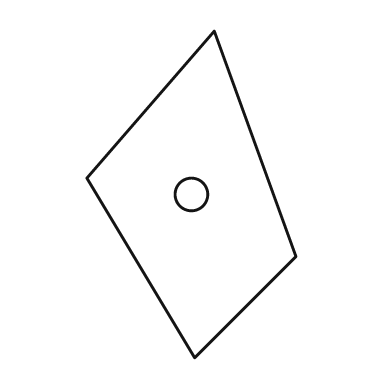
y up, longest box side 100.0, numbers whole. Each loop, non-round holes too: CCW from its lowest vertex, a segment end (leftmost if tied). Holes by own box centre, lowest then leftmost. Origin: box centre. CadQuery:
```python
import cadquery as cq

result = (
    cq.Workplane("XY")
    .moveTo(1.0, -50.0)
    .lineTo(32.0, -19.0)
    .lineTo(7.0, 50.0)
    .lineTo(-32.0, 5.0)
    .close()
    .moveTo(0.0, 0.0)
    .circle(5.0)
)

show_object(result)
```